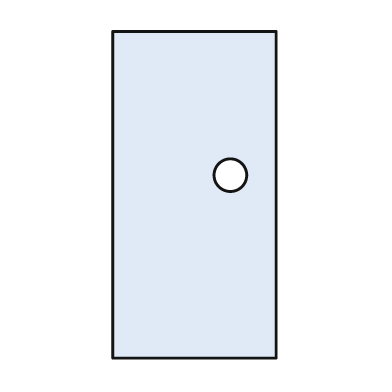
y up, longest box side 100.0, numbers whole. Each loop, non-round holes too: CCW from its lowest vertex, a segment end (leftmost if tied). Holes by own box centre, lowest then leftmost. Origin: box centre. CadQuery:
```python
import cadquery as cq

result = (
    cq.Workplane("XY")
    .moveTo(-25.0, -50.0)
    .lineTo(25.0, -50.0)
    .lineTo(25.0, 50.0)
    .lineTo(-25.0, 50.0)
    .close()
    .moveTo(11.0, 6.0)
    .circle(5.0)
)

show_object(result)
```